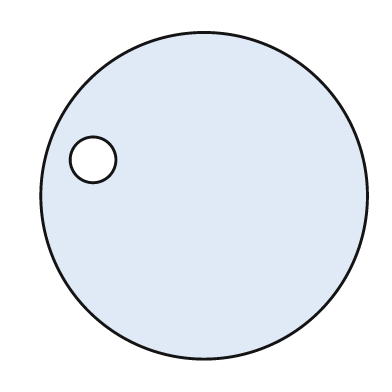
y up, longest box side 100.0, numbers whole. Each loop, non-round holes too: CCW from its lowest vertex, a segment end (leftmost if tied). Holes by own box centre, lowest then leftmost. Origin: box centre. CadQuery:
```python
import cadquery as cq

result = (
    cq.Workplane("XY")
    .moveTo(0.0, 0.0)
    .circle(50.0)
    .moveTo(-34.0, 11.0)
    .circle(7.0)
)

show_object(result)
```